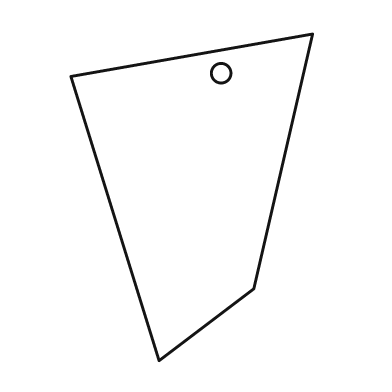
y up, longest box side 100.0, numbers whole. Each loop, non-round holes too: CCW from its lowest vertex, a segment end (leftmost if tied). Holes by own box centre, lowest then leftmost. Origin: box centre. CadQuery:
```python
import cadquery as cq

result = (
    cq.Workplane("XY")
    .moveTo(-10.0, -50.0)
    .lineTo(19.0, -28.0)
    .lineTo(37.0, 50.0)
    .lineTo(-37.0, 37.0)
    .close()
    .moveTo(9.0, 38.0)
    .circle(3.0)
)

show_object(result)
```